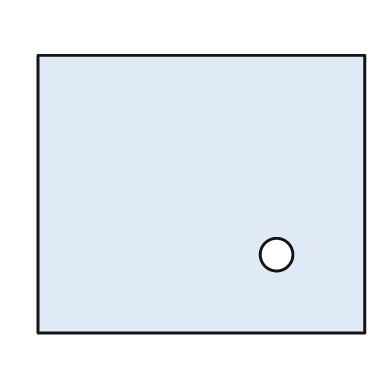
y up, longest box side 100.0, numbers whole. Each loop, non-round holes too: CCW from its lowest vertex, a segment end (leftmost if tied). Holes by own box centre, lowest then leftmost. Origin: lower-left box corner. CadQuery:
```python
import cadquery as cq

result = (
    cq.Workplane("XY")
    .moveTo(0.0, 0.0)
    .lineTo(100.0, 0.0)
    .lineTo(100.0, 85.0)
    .lineTo(0.0, 85.0)
    .close()
    .moveTo(73.0, 24.0)
    .circle(5.0)
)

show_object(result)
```